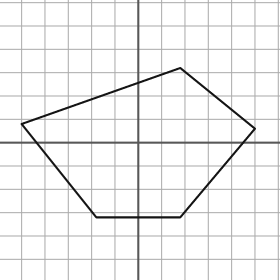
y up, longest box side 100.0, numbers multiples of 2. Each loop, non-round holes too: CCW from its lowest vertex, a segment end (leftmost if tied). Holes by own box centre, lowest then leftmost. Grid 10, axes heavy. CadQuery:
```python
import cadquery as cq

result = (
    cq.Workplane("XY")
    .moveTo(-18.0, -32.0)
    .lineTo(18.0, -32.0)
    .lineTo(50.0, 6.0)
    .lineTo(18.0, 32.0)
    .lineTo(-50.0, 8.0)
    .close()
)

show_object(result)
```